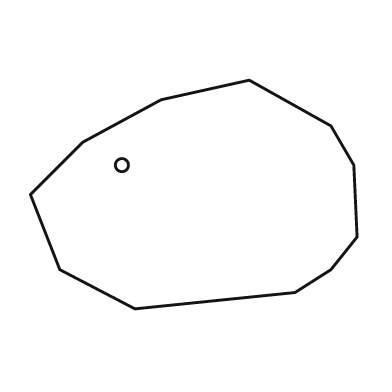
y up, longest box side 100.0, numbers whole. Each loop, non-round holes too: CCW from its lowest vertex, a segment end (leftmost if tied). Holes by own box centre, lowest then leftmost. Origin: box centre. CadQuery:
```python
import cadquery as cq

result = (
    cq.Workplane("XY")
    .moveTo(-18.0, -35.0)
    .lineTo(31.0, -30.0)
    .lineTo(42.0, -23.0)
    .lineTo(50.0, -13.0)
    .lineTo(49.0, 9.0)
    .lineTo(42.0, 21.0)
    .lineTo(17.0, 35.0)
    .lineTo(-10.0, 29.0)
    .lineTo(-34.0, 16.0)
    .lineTo(-50.0, 0.0)
    .lineTo(-41.0, -23.0)
    .close()
    .moveTo(-22.0, 9.0)
    .circle(2.0)
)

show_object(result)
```